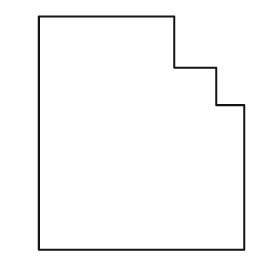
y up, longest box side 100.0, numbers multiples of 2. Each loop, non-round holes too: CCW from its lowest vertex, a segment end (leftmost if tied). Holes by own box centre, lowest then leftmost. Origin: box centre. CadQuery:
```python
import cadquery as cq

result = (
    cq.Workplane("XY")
    .moveTo(-44.0, -50.0)
    .lineTo(44.0, -50.0)
    .lineTo(44.0, 12.0)
    .lineTo(32.0, 12.0)
    .lineTo(32.0, 28.0)
    .lineTo(14.0, 28.0)
    .lineTo(14.0, 50.0)
    .lineTo(-44.0, 50.0)
    .close()
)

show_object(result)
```